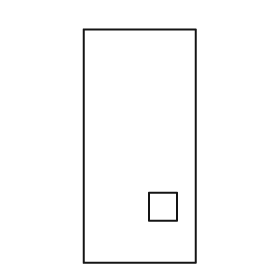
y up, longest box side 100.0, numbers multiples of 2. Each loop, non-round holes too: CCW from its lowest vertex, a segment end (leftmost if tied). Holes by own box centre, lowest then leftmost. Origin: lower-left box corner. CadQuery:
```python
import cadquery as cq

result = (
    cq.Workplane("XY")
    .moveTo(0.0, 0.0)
    .lineTo(48.0, 0.0)
    .lineTo(48.0, 100.0)
    .lineTo(0.0, 100.0)
    .close()
    .moveTo(28.0, 18.0)
    .lineTo(40.0, 18.0)
    .lineTo(40.0, 30.0)
    .lineTo(28.0, 30.0)
    .close()
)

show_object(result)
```